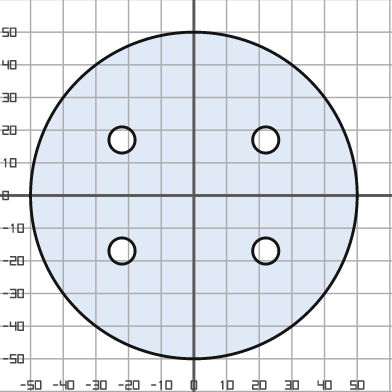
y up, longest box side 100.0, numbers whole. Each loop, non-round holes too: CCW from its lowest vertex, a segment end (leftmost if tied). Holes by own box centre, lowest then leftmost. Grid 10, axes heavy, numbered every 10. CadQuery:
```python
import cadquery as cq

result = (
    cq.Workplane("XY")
    .moveTo(0.0, 0.0)
    .circle(50.0)
    .moveTo(-22.0, -17.0)
    .circle(4.0)
    .moveTo(22.0, -17.0)
    .circle(4.0)
    .moveTo(-22.0, 17.0)
    .circle(4.0)
    .moveTo(22.0, 17.0)
    .circle(4.0)
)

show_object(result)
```